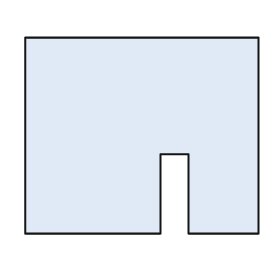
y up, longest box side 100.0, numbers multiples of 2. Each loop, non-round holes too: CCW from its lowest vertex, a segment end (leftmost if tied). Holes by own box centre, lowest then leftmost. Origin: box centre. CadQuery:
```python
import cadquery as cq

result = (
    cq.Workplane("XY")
    .moveTo(-50.0, -42.0)
    .lineTo(8.0, -42.0)
    .lineTo(8.0, -8.0)
    .lineTo(20.0, -8.0)
    .lineTo(20.0, -42.0)
    .lineTo(50.0, -42.0)
    .lineTo(50.0, 42.0)
    .lineTo(-50.0, 42.0)
    .close()
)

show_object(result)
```